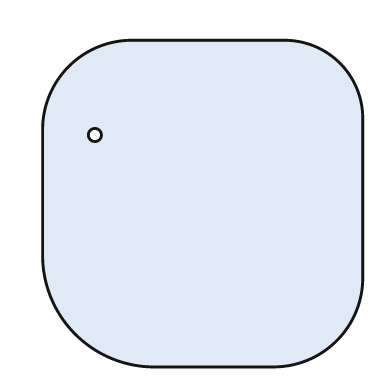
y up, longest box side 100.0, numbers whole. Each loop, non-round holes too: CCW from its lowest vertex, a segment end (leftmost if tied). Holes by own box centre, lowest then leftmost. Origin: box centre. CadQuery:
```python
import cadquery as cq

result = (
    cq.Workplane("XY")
    .moveTo(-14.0, -50.0)
    .lineTo(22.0, -50.0)
    .threePointArc((41.0, -42.0), (49.0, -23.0))
    .lineTo(49.0, 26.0)
    .threePointArc((42.0, 43.0), (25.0, 50.0))
    .lineTo(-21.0, 50.0)
    .threePointArc((-41.0, 42.0), (-49.0, 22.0))
    .lineTo(-49.0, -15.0)
    .threePointArc((-39.0, -40.0), (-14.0, -50.0))
    .close()
    .moveTo(-33.0, 21.0)
    .circle(2.0)
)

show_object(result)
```